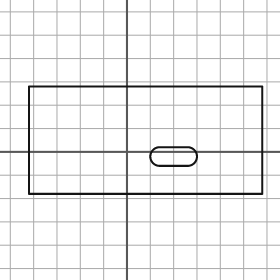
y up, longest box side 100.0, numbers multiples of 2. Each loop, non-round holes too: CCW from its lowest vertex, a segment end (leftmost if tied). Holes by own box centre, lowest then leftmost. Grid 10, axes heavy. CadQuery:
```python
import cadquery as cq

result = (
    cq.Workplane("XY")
    .moveTo(-42.0, -18.0)
    .lineTo(58.0, -18.0)
    .lineTo(58.0, 28.0)
    .lineTo(-42.0, 28.0)
    .close()
    .moveTo(14.0, -6.0)
    .lineTo(26.0, -6.0)
    .threePointArc((30.0, -2.0), (26.0, 2.0))
    .lineTo(14.0, 2.0)
    .threePointArc((10.0, -2.0), (14.0, -6.0))
    .close()
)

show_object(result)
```